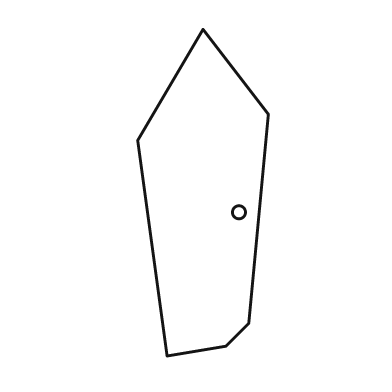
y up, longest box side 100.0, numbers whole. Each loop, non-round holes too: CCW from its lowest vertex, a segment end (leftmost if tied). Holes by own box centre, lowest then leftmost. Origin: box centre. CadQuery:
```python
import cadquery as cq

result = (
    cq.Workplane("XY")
    .moveTo(-11.0, -50.0)
    .lineTo(7.0, -47.0)
    .lineTo(14.0, -40.0)
    .lineTo(20.0, 24.0)
    .lineTo(0.0, 50.0)
    .lineTo(-20.0, 16.0)
    .close()
    .moveTo(11.0, -6.0)
    .circle(2.0)
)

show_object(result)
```